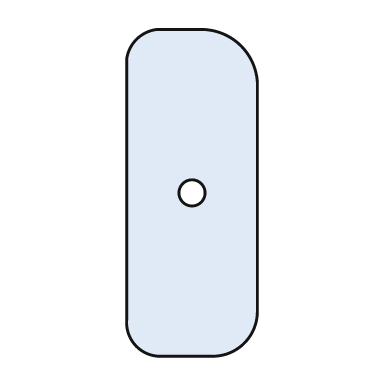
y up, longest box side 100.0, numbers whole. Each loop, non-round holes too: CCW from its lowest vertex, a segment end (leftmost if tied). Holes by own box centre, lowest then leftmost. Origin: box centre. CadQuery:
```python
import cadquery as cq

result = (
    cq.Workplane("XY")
    .moveTo(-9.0, -50.0)
    .lineTo(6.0, -50.0)
    .threePointArc((16.0, -46.0), (20.0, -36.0))
    .lineTo(20.0, 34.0)
    .threePointArc((15.0, 45.0), (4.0, 50.0))
    .lineTo(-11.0, 50.0)
    .threePointArc((-17.0, 47.0), (-20.0, 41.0))
    .lineTo(-20.0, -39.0)
    .threePointArc((-17.0, -47.0), (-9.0, -50.0))
    .close()
    .moveTo(0.0, 0.0)
    .circle(4.0)
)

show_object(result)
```